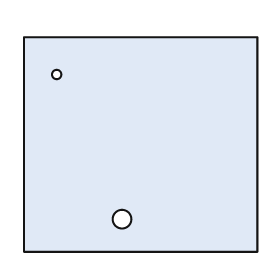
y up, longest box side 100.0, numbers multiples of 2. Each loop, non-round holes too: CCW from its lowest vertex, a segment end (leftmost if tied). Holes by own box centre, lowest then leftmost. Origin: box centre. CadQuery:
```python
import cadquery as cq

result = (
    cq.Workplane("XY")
    .moveTo(-50.0, -46.0)
    .lineTo(50.0, -46.0)
    .lineTo(50.0, 46.0)
    .lineTo(-50.0, 46.0)
    .close()
    .moveTo(-8.0, -32.0)
    .circle(4.0)
    .moveTo(-36.0, 30.0)
    .circle(2.0)
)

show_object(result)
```